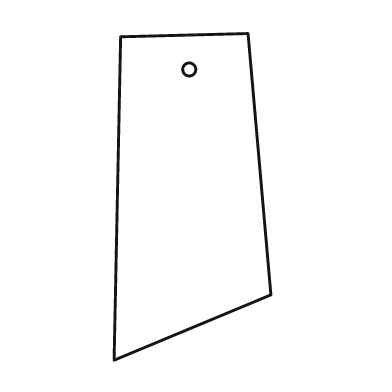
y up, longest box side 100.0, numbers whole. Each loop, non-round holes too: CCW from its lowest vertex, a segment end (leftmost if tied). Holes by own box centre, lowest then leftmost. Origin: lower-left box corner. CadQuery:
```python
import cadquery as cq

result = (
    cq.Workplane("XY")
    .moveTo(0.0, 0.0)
    .lineTo(48.0, 20.0)
    .lineTo(41.0, 100.0)
    .lineTo(2.0, 99.0)
    .close()
    .moveTo(23.0, 89.0)
    .circle(2.0)
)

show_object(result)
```